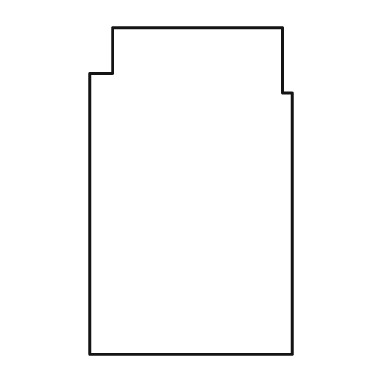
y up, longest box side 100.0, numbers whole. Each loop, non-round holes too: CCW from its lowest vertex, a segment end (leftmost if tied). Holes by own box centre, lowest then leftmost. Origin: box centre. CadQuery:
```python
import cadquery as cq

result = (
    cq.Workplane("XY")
    .moveTo(-31.0, -50.0)
    .lineTo(31.0, -50.0)
    .lineTo(31.0, 30.0)
    .lineTo(28.0, 30.0)
    .lineTo(28.0, 50.0)
    .lineTo(-24.0, 50.0)
    .lineTo(-24.0, 36.0)
    .lineTo(-31.0, 36.0)
    .close()
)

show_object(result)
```